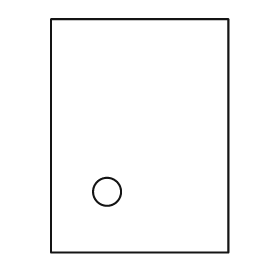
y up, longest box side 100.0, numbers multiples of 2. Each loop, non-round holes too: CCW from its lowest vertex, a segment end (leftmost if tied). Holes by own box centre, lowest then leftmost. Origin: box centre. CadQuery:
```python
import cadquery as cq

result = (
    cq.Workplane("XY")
    .moveTo(-38.0, -50.0)
    .lineTo(38.0, -50.0)
    .lineTo(38.0, 50.0)
    .lineTo(-38.0, 50.0)
    .close()
    .moveTo(-14.0, -24.0)
    .circle(6.0)
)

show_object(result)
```